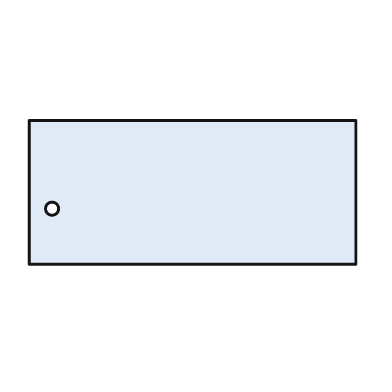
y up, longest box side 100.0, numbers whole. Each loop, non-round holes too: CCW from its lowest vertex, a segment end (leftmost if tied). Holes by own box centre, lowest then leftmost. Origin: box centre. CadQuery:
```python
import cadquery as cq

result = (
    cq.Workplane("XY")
    .moveTo(-50.0, -22.0)
    .lineTo(50.0, -22.0)
    .lineTo(50.0, 22.0)
    .lineTo(-50.0, 22.0)
    .close()
    .moveTo(-43.0, -5.0)
    .circle(2.0)
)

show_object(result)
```